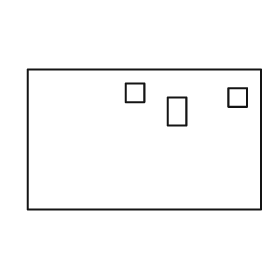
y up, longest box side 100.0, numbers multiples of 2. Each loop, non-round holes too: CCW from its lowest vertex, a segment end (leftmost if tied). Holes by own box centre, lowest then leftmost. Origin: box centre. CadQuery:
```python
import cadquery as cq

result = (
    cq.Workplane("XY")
    .moveTo(-50.0, -30.0)
    .lineTo(50.0, -30.0)
    .lineTo(50.0, 30.0)
    .lineTo(-50.0, 30.0)
    .close()
    .moveTo(10.0, 6.0)
    .lineTo(18.0, 6.0)
    .lineTo(18.0, 18.0)
    .lineTo(10.0, 18.0)
    .close()
    .moveTo(36.0, 14.0)
    .lineTo(44.0, 14.0)
    .lineTo(44.0, 22.0)
    .lineTo(36.0, 22.0)
    .close()
    .moveTo(-8.0, 16.0)
    .lineTo(0.0, 16.0)
    .lineTo(0.0, 24.0)
    .lineTo(-8.0, 24.0)
    .close()
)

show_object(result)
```